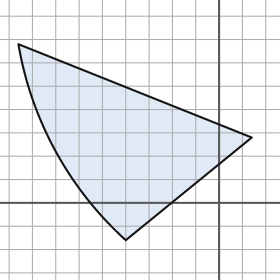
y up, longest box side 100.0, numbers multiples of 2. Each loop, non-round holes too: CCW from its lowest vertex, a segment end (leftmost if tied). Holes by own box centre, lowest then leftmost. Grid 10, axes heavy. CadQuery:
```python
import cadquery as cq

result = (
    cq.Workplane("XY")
    .moveTo(-40.0, -16.0)
    .lineTo(14.0, 28.0)
    .lineTo(-86.0, 68.0)
    .threePointArc((-70.0, 22.0), (-40.0, -16.0))
    .close()
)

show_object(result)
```